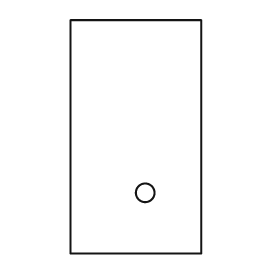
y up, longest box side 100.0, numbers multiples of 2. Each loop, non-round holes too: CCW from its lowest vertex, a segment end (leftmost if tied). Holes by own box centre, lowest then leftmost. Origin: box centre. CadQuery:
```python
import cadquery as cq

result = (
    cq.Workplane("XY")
    .moveTo(-28.0, -50.0)
    .lineTo(28.0, -50.0)
    .lineTo(28.0, 50.0)
    .lineTo(-28.0, 50.0)
    .close()
    .moveTo(4.0, -24.0)
    .circle(4.0)
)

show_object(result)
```